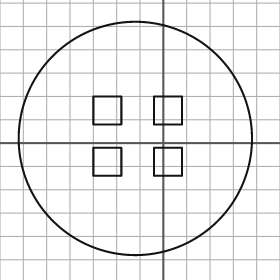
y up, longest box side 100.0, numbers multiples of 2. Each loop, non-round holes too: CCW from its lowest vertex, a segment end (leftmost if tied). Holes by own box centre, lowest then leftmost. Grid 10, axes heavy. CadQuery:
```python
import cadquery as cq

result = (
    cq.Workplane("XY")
    .moveTo(-12.0, 2.0)
    .circle(50.0)
    .moveTo(-30.0, -14.0)
    .lineTo(-18.0, -14.0)
    .lineTo(-18.0, -2.0)
    .lineTo(-30.0, -2.0)
    .close()
    .moveTo(-4.0, -14.0)
    .lineTo(8.0, -14.0)
    .lineTo(8.0, -2.0)
    .lineTo(-4.0, -2.0)
    .close()
    .moveTo(-30.0, 8.0)
    .lineTo(-18.0, 8.0)
    .lineTo(-18.0, 20.0)
    .lineTo(-30.0, 20.0)
    .close()
    .moveTo(-4.0, 8.0)
    .lineTo(8.0, 8.0)
    .lineTo(8.0, 20.0)
    .lineTo(-4.0, 20.0)
    .close()
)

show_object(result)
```